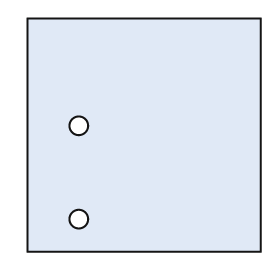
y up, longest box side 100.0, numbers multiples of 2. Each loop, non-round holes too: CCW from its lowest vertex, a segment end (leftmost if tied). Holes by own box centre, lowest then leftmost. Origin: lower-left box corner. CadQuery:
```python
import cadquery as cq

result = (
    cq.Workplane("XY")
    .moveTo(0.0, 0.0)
    .lineTo(100.0, 0.0)
    .lineTo(100.0, 100.0)
    .lineTo(0.0, 100.0)
    .close()
    .moveTo(22.0, 14.0)
    .circle(4.0)
    .moveTo(22.0, 54.0)
    .circle(4.0)
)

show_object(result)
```